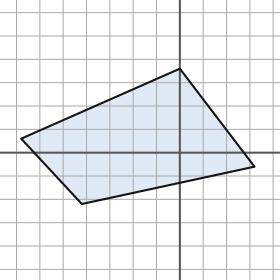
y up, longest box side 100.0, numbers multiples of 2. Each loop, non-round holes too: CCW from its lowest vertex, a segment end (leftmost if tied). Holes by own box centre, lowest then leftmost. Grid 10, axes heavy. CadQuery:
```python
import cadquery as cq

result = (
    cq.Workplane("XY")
    .moveTo(-42.0, -22.0)
    .lineTo(32.0, -6.0)
    .lineTo(0.0, 36.0)
    .lineTo(-68.0, 6.0)
    .close()
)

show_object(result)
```